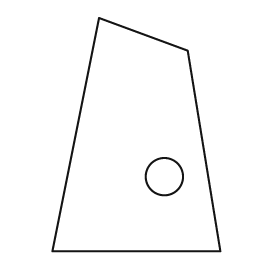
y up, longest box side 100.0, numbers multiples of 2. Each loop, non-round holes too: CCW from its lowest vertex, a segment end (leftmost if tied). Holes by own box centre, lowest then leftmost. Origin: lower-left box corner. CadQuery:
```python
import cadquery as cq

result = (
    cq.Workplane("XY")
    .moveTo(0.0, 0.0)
    .lineTo(72.0, 0.0)
    .lineTo(58.0, 86.0)
    .lineTo(20.0, 100.0)
    .close()
    .moveTo(48.0, 32.0)
    .circle(8.0)
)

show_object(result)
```